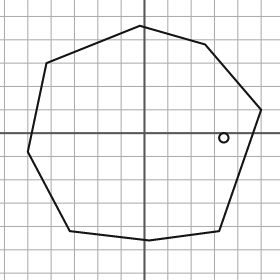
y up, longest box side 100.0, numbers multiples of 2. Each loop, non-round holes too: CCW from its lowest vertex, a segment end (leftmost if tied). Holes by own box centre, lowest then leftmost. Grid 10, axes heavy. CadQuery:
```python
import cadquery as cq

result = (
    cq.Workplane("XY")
    .moveTo(2.0, -46.0)
    .lineTo(32.0, -42.0)
    .lineTo(50.0, 10.0)
    .lineTo(26.0, 38.0)
    .lineTo(-2.0, 46.0)
    .lineTo(-42.0, 30.0)
    .lineTo(-50.0, -8.0)
    .lineTo(-32.0, -42.0)
    .close()
    .moveTo(34.0, -2.0)
    .circle(2.0)
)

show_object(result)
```